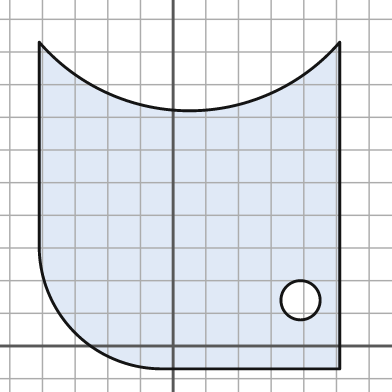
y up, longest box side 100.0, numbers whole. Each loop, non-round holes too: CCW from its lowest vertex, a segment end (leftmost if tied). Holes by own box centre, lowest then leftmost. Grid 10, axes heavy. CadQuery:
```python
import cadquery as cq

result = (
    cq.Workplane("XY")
    .moveTo(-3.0, -7.0)
    .lineTo(51.0, -7.0)
    .lineTo(51.0, 93.0)
    .threePointArc((5.0, 72.0), (-41.0, 93.0))
    .lineTo(-41.0, 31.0)
    .threePointArc((-30.0, 4.0), (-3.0, -7.0))
    .close()
    .moveTo(39.0, 14.0)
    .circle(6.0)
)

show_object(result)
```